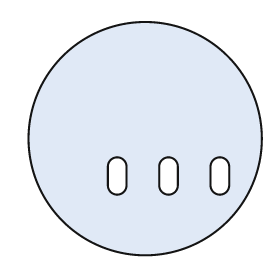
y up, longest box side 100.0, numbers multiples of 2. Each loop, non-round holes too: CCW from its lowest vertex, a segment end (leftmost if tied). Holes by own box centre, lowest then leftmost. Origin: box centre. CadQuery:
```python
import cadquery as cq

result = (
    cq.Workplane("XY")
    .moveTo(0.0, 0.0)
    .circle(50.0)
    .moveTo(-16.0, -20.0)
    .threePointArc((-12.0, -24.0), (-8.0, -20.0))
    .lineTo(-8.0, -12.0)
    .threePointArc((-12.0, -8.0), (-16.0, -12.0))
    .close()
    .moveTo(6.0, -20.0)
    .threePointArc((10.0, -24.0), (14.0, -20.0))
    .lineTo(14.0, -12.0)
    .threePointArc((10.0, -8.0), (6.0, -12.0))
    .close()
    .moveTo(28.0, -20.0)
    .threePointArc((32.0, -24.0), (36.0, -20.0))
    .lineTo(36.0, -12.0)
    .threePointArc((32.0, -8.0), (28.0, -12.0))
    .close()
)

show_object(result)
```